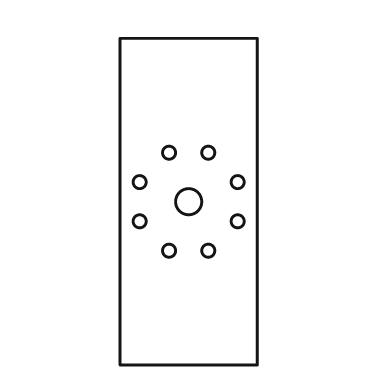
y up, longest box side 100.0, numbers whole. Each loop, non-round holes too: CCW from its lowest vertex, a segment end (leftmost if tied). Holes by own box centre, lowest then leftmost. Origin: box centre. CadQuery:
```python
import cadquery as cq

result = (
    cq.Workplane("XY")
    .moveTo(-21.0, -50.0)
    .lineTo(21.0, -50.0)
    .lineTo(21.0, 50.0)
    .lineTo(-21.0, 50.0)
    .close()
    .moveTo(-6.0, -15.0)
    .circle(2.0)
    .moveTo(6.0, -15.0)
    .circle(2.0)
    .moveTo(-15.0, -6.0)
    .circle(2.0)
    .moveTo(15.0, -6.0)
    .circle(2.0)
    .moveTo(0.0, 0.0)
    .circle(4.0)
    .moveTo(-15.0, 6.0)
    .circle(2.0)
    .moveTo(15.0, 6.0)
    .circle(2.0)
    .moveTo(-6.0, 15.0)
    .circle(2.0)
    .moveTo(6.0, 15.0)
    .circle(2.0)
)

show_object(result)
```